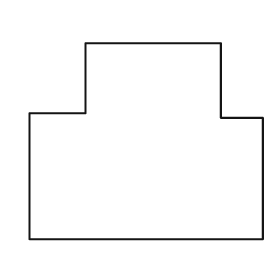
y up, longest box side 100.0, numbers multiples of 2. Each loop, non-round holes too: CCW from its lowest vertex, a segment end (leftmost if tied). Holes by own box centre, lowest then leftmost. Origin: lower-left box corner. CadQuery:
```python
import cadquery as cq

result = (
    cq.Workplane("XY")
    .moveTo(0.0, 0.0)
    .lineTo(100.0, 0.0)
    .lineTo(100.0, 52.0)
    .lineTo(82.0, 52.0)
    .lineTo(82.0, 84.0)
    .lineTo(24.0, 84.0)
    .lineTo(24.0, 54.0)
    .lineTo(0.0, 54.0)
    .close()
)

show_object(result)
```